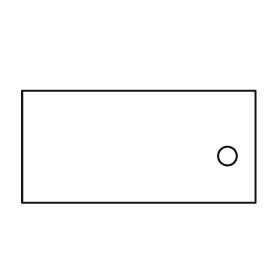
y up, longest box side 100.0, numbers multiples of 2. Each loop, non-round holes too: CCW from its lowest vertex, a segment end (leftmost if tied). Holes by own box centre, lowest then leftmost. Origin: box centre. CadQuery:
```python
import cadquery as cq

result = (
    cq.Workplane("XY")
    .moveTo(-50.0, -24.0)
    .lineTo(50.0, -24.0)
    .lineTo(50.0, 24.0)
    .lineTo(-50.0, 24.0)
    .close()
    .moveTo(38.0, -4.0)
    .circle(4.0)
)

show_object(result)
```